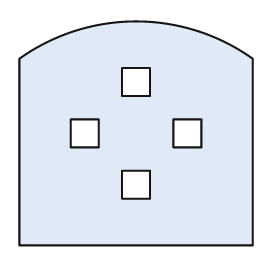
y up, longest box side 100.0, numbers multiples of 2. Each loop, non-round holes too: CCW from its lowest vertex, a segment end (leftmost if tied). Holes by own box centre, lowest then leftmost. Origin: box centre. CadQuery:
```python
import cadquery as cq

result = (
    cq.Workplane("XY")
    .moveTo(-50.0, -48.0)
    .lineTo(50.0, -48.0)
    .lineTo(50.0, 32.0)
    .threePointArc((0.0, 48.0), (-50.0, 32.0))
    .close()
    .moveTo(-6.0, -28.0)
    .lineTo(6.0, -28.0)
    .lineTo(6.0, -16.0)
    .lineTo(-6.0, -16.0)
    .close()
    .moveTo(-28.0, -6.0)
    .lineTo(-16.0, -6.0)
    .lineTo(-16.0, 6.0)
    .lineTo(-28.0, 6.0)
    .close()
    .moveTo(16.0, -6.0)
    .lineTo(28.0, -6.0)
    .lineTo(28.0, 6.0)
    .lineTo(16.0, 6.0)
    .close()
    .moveTo(-6.0, 16.0)
    .lineTo(6.0, 16.0)
    .lineTo(6.0, 28.0)
    .lineTo(-6.0, 28.0)
    .close()
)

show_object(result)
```